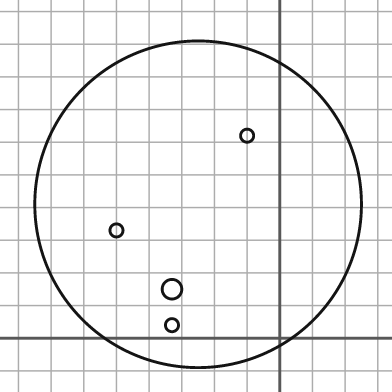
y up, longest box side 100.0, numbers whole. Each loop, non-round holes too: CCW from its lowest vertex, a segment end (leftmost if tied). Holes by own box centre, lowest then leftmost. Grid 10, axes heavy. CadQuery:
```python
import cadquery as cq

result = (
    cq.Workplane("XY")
    .moveTo(-25.0, 41.0)
    .circle(50.0)
    .moveTo(-33.0, 4.0)
    .circle(2.0)
    .moveTo(-33.0, 15.0)
    .circle(3.0)
    .moveTo(-50.0, 33.0)
    .circle(2.0)
    .moveTo(-10.0, 62.0)
    .circle(2.0)
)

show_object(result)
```